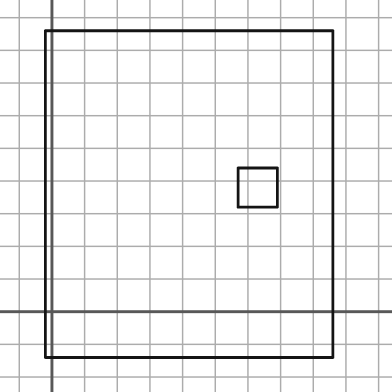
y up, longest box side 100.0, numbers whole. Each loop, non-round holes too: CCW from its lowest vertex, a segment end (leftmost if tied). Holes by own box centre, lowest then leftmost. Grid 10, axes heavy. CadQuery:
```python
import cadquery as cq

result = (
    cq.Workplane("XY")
    .moveTo(-2.0, -14.0)
    .lineTo(86.0, -14.0)
    .lineTo(86.0, 86.0)
    .lineTo(-2.0, 86.0)
    .close()
    .moveTo(57.0, 32.0)
    .lineTo(69.0, 32.0)
    .lineTo(69.0, 44.0)
    .lineTo(57.0, 44.0)
    .close()
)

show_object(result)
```